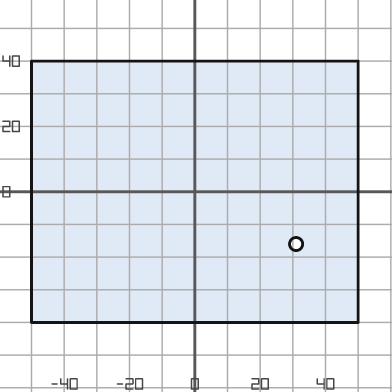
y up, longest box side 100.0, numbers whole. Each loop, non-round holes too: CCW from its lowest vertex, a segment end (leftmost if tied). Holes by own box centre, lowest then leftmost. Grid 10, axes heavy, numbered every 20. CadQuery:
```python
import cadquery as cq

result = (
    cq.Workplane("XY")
    .moveTo(-50.0, -40.0)
    .lineTo(50.0, -40.0)
    .lineTo(50.0, 40.0)
    .lineTo(-50.0, 40.0)
    .close()
    .moveTo(31.0, -16.0)
    .circle(2.0)
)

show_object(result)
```